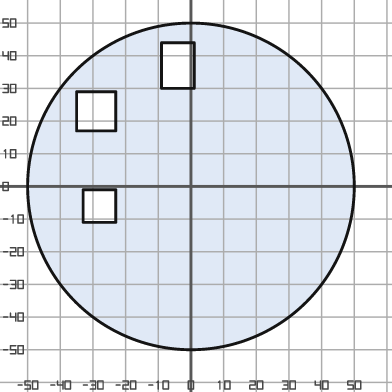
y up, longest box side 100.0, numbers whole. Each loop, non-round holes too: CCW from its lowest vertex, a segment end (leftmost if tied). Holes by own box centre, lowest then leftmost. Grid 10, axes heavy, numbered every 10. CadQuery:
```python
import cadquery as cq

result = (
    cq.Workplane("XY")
    .moveTo(0.0, 0.0)
    .circle(50.0)
    .moveTo(-33.0, -11.0)
    .lineTo(-23.0, -11.0)
    .lineTo(-23.0, -1.0)
    .lineTo(-33.0, -1.0)
    .close()
    .moveTo(-35.0, 17.0)
    .lineTo(-23.0, 17.0)
    .lineTo(-23.0, 29.0)
    .lineTo(-35.0, 29.0)
    .close()
    .moveTo(-9.0, 30.0)
    .lineTo(1.0, 30.0)
    .lineTo(1.0, 44.0)
    .lineTo(-9.0, 44.0)
    .close()
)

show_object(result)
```